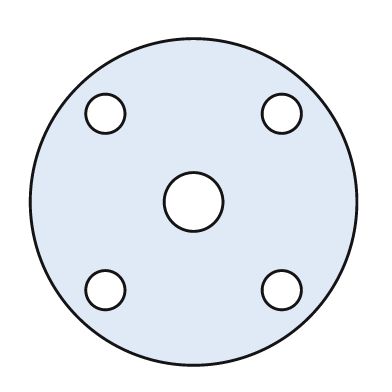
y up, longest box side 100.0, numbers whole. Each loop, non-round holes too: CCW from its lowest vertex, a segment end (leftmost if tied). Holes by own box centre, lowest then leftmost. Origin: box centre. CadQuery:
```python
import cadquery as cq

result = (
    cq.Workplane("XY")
    .moveTo(0.0, 0.0)
    .circle(50.0)
    .moveTo(-27.0, -27.0)
    .circle(6.0)
    .moveTo(27.0, -27.0)
    .circle(6.0)
    .moveTo(0.0, 0.0)
    .circle(9.0)
    .moveTo(-27.0, 27.0)
    .circle(6.0)
    .moveTo(27.0, 27.0)
    .circle(6.0)
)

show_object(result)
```